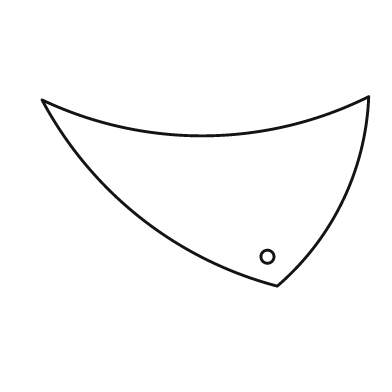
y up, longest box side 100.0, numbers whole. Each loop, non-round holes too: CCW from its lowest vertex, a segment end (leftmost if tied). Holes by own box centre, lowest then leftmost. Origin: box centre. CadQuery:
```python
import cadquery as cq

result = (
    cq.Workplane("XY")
    .moveTo(22.0, -29.0)
    .threePointArc((42.0, -3.0), (50.0, 29.0))
    .threePointArc((0.0, 17.0), (-50.0, 28.0))
    .threePointArc((-20.0, -8.0), (22.0, -29.0))
    .close()
    .moveTo(19.0, -20.0)
    .circle(2.0)
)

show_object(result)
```